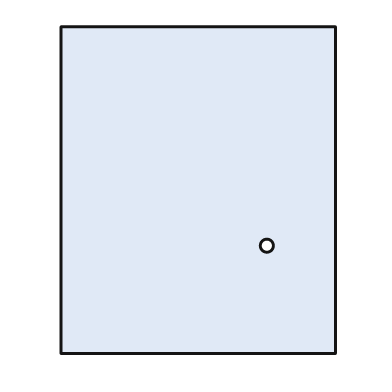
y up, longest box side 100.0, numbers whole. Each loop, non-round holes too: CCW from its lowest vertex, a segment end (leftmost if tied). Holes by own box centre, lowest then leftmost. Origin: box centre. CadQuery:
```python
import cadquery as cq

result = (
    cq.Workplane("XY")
    .moveTo(-42.0, -50.0)
    .lineTo(42.0, -50.0)
    .lineTo(42.0, 50.0)
    .lineTo(-42.0, 50.0)
    .close()
    .moveTo(21.0, -17.0)
    .circle(2.0)
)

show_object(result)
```